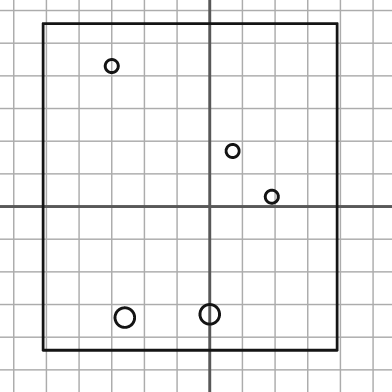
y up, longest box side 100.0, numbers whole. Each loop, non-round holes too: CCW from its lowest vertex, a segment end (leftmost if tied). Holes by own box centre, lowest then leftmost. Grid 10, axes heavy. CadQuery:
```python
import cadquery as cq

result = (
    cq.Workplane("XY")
    .moveTo(-51.0, -44.0)
    .lineTo(39.0, -44.0)
    .lineTo(39.0, 56.0)
    .lineTo(-51.0, 56.0)
    .close()
    .moveTo(-26.0, -34.0)
    .circle(3.0)
    .moveTo(0.0, -33.0)
    .circle(3.0)
    .moveTo(19.0, 3.0)
    .circle(2.0)
    .moveTo(7.0, 17.0)
    .circle(2.0)
    .moveTo(-30.0, 43.0)
    .circle(2.0)
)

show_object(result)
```